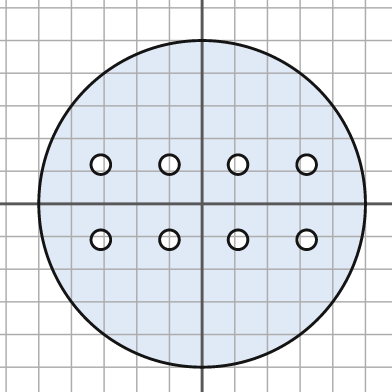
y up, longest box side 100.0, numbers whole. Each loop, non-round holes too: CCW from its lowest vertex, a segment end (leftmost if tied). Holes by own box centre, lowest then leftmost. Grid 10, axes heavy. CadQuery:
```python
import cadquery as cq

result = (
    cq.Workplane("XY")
    .moveTo(0.0, 0.0)
    .circle(50.0)
    .moveTo(-31.0, -11.0)
    .circle(3.0)
    .moveTo(-10.0, -11.0)
    .circle(3.0)
    .moveTo(11.0, -11.0)
    .circle(3.0)
    .moveTo(32.0, -11.0)
    .circle(3.0)
    .moveTo(-31.0, 12.0)
    .circle(3.0)
    .moveTo(-10.0, 12.0)
    .circle(3.0)
    .moveTo(11.0, 12.0)
    .circle(3.0)
    .moveTo(32.0, 12.0)
    .circle(3.0)
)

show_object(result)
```